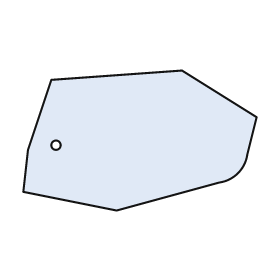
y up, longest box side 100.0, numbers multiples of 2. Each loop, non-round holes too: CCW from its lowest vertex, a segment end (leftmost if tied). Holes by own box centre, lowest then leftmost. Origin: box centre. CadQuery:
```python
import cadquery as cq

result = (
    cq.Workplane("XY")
    .moveTo(-10.0, -30.0)
    .lineTo(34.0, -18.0)
    .threePointArc((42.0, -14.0), (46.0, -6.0))
    .lineTo(50.0, 10.0)
    .lineTo(18.0, 30.0)
    .lineTo(-38.0, 26.0)
    .lineTo(-48.0, -4.0)
    .lineTo(-50.0, -22.0)
    .close()
    .moveTo(-36.0, -2.0)
    .circle(2.0)
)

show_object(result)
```